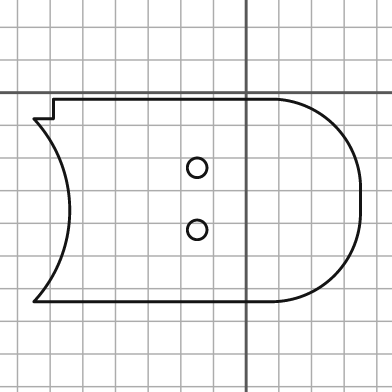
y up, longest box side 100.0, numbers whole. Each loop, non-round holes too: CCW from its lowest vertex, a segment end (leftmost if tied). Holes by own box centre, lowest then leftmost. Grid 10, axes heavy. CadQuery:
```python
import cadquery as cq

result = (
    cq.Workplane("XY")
    .moveTo(-65.0, -64.0)
    .lineTo(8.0, -64.0)
    .threePointArc((27.0, -56.0), (35.0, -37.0))
    .lineTo(35.0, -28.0)
    .threePointArc((27.0, -10.0), (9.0, -2.0))
    .lineTo(-59.0, -2.0)
    .lineTo(-59.0, -8.0)
    .lineTo(-65.0, -8.0)
    .threePointArc((-54.0, -36.0), (-65.0, -64.0))
    .close()
    .moveTo(-15.0, -42.0)
    .circle(3.0)
    .moveTo(-15.0, -23.0)
    .circle(3.0)
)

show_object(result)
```